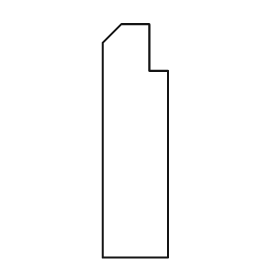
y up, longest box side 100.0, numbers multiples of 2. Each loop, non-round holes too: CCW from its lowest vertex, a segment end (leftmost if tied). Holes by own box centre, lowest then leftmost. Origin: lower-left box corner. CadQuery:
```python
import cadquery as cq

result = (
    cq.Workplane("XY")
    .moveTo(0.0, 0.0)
    .lineTo(28.0, 0.0)
    .lineTo(28.0, 80.0)
    .lineTo(20.0, 80.0)
    .lineTo(20.0, 100.0)
    .lineTo(8.0, 100.0)
    .lineTo(0.0, 92.0)
    .close()
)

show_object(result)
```